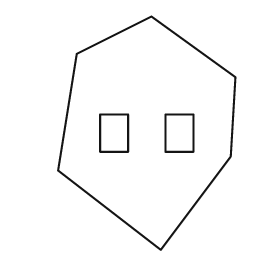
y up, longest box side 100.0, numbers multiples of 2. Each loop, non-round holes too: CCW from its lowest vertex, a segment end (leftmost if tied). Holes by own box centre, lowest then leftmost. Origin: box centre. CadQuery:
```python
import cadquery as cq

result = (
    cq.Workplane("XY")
    .moveTo(6.0, -50.0)
    .lineTo(36.0, -10.0)
    .lineTo(38.0, 24.0)
    .lineTo(2.0, 50.0)
    .lineTo(-30.0, 34.0)
    .lineTo(-38.0, -16.0)
    .close()
    .moveTo(-20.0, -8.0)
    .lineTo(-8.0, -8.0)
    .lineTo(-8.0, 8.0)
    .lineTo(-20.0, 8.0)
    .close()
    .moveTo(8.0, -8.0)
    .lineTo(20.0, -8.0)
    .lineTo(20.0, 8.0)
    .lineTo(8.0, 8.0)
    .close()
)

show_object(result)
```